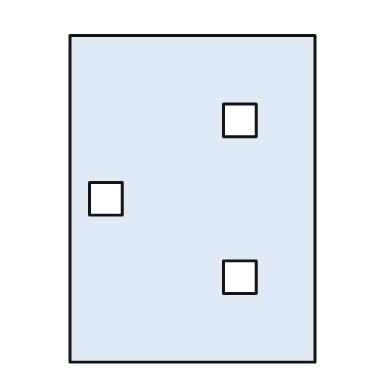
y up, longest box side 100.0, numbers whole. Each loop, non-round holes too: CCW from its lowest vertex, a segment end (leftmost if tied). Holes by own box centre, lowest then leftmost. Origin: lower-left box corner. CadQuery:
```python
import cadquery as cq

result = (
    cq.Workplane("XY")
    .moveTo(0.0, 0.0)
    .lineTo(75.0, 0.0)
    .lineTo(75.0, 100.0)
    .lineTo(0.0, 100.0)
    .close()
    .moveTo(47.0, 21.0)
    .lineTo(57.0, 21.0)
    .lineTo(57.0, 31.0)
    .lineTo(47.0, 31.0)
    .close()
    .moveTo(6.0, 45.0)
    .lineTo(16.0, 45.0)
    .lineTo(16.0, 55.0)
    .lineTo(6.0, 55.0)
    .close()
    .moveTo(47.0, 69.0)
    .lineTo(57.0, 69.0)
    .lineTo(57.0, 79.0)
    .lineTo(47.0, 79.0)
    .close()
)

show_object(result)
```